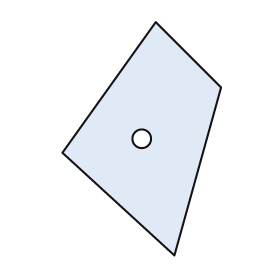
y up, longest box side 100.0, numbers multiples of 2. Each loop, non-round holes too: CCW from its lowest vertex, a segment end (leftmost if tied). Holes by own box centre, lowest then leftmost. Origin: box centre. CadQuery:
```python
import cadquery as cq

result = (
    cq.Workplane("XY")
    .moveTo(14.0, -50.0)
    .lineTo(34.0, 22.0)
    .lineTo(6.0, 50.0)
    .lineTo(-34.0, -6.0)
    .close()
    .moveTo(0.0, 0.0)
    .circle(4.0)
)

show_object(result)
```